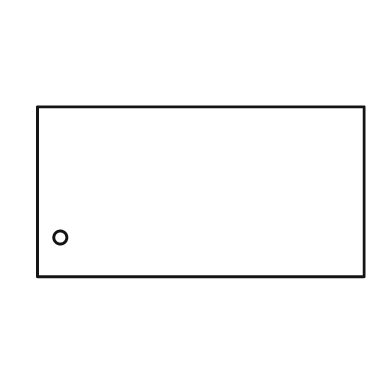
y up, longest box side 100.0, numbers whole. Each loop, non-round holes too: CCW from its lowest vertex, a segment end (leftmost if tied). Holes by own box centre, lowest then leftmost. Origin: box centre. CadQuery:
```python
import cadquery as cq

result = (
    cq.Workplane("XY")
    .moveTo(-50.0, -26.0)
    .lineTo(50.0, -26.0)
    .lineTo(50.0, 26.0)
    .lineTo(-50.0, 26.0)
    .close()
    .moveTo(-43.0, -14.0)
    .circle(2.0)
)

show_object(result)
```